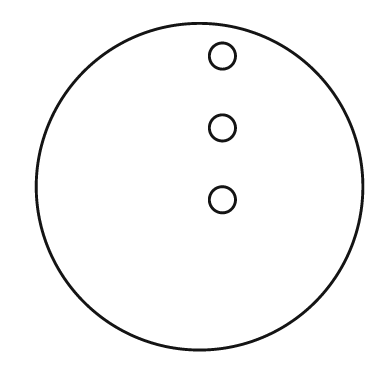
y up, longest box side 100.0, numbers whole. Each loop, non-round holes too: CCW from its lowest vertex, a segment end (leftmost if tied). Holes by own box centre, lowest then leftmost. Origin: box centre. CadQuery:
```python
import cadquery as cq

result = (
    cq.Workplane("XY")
    .moveTo(0.0, 0.0)
    .circle(50.0)
    .moveTo(7.0, -4.0)
    .circle(4.0)
    .moveTo(7.0, 18.0)
    .circle(4.0)
    .moveTo(7.0, 40.0)
    .circle(4.0)
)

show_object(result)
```